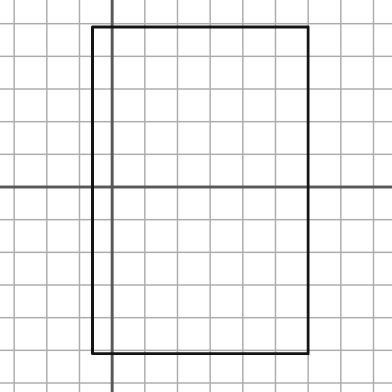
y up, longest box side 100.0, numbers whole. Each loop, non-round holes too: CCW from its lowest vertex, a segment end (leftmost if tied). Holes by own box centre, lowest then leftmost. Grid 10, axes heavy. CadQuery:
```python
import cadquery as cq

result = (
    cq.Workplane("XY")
    .moveTo(-6.0, -51.0)
    .lineTo(60.0, -51.0)
    .lineTo(60.0, 49.0)
    .lineTo(-6.0, 49.0)
    .close()
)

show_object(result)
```